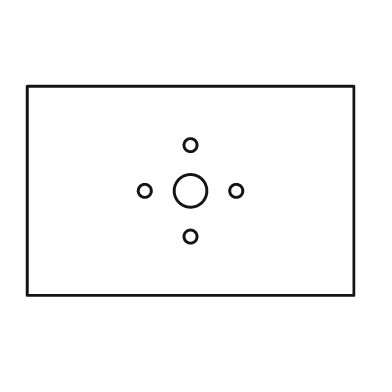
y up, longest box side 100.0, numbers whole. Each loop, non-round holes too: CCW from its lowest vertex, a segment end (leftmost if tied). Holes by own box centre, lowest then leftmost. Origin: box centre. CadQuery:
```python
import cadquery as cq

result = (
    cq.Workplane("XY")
    .moveTo(-50.0, -32.0)
    .lineTo(50.0, -32.0)
    .lineTo(50.0, 32.0)
    .lineTo(-50.0, 32.0)
    .close()
    .moveTo(0.0, -14.0)
    .circle(2.0)
    .moveTo(-14.0, 0.0)
    .circle(2.0)
    .moveTo(0.0, 0.0)
    .circle(5.0)
    .moveTo(14.0, 0.0)
    .circle(2.0)
    .moveTo(0.0, 14.0)
    .circle(2.0)
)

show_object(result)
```